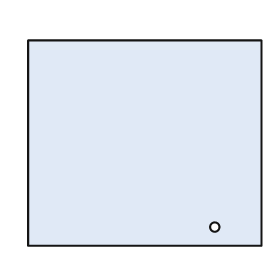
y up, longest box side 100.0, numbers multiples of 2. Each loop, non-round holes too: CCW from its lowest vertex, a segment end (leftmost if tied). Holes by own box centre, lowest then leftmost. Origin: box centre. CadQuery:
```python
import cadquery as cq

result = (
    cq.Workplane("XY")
    .moveTo(-50.0, -44.0)
    .lineTo(50.0, -44.0)
    .lineTo(50.0, 44.0)
    .lineTo(-50.0, 44.0)
    .close()
    .moveTo(30.0, -36.0)
    .circle(2.0)
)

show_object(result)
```